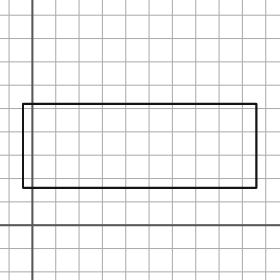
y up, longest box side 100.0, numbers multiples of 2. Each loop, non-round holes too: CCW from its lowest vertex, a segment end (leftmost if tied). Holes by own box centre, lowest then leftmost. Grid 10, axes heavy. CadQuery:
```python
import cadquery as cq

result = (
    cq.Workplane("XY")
    .moveTo(-4.0, 16.0)
    .lineTo(96.0, 16.0)
    .lineTo(96.0, 52.0)
    .lineTo(-4.0, 52.0)
    .close()
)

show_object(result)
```